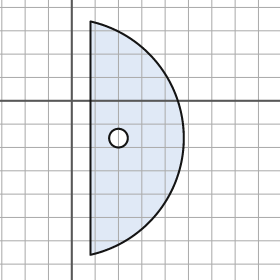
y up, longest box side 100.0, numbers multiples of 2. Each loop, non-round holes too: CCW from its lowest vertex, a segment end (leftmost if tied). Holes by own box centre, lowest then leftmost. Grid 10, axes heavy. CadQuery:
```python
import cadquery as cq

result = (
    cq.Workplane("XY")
    .moveTo(8.0, -66.0)
    .threePointArc((48.0, -16.0), (8.0, 34.0))
    .close()
    .moveTo(20.0, -16.0)
    .circle(4.0)
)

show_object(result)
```